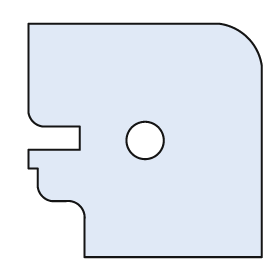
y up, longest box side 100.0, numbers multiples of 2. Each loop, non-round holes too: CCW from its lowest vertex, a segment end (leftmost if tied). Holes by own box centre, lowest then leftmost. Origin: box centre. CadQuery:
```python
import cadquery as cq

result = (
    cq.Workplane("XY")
    .moveTo(-26.0, -50.0)
    .lineTo(50.0, -50.0)
    .lineTo(50.0, 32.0)
    .threePointArc((44.0, 44.0), (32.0, 50.0))
    .lineTo(-50.0, 50.0)
    .lineTo(-50.0, 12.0)
    .threePointArc((-48.0, 8.0), (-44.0, 6.0))
    .lineTo(-28.0, 6.0)
    .lineTo(-28.0, -4.0)
    .lineTo(-50.0, -4.0)
    .lineTo(-50.0, -12.0)
    .lineTo(-46.0, -12.0)
    .lineTo(-46.0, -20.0)
    .threePointArc((-44.0, -24.0), (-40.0, -26.0))
    .lineTo(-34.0, -26.0)
    .threePointArc((-28.0, -28.0), (-26.0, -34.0))
    .close()
    .moveTo(0.0, 0.0)
    .circle(8.0)
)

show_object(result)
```